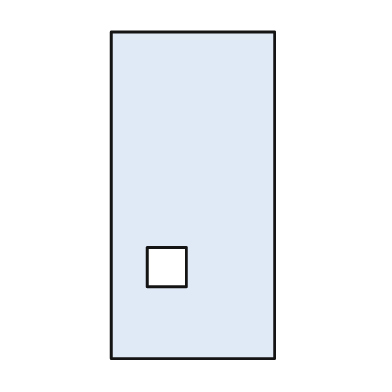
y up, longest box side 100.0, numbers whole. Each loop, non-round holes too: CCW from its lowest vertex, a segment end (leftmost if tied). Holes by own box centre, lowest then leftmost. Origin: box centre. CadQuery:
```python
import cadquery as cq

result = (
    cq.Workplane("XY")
    .moveTo(-25.0, -50.0)
    .lineTo(25.0, -50.0)
    .lineTo(25.0, 50.0)
    .lineTo(-25.0, 50.0)
    .close()
    .moveTo(-14.0, -28.0)
    .lineTo(-2.0, -28.0)
    .lineTo(-2.0, -16.0)
    .lineTo(-14.0, -16.0)
    .close()
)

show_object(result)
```